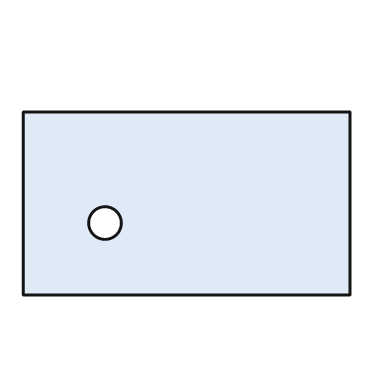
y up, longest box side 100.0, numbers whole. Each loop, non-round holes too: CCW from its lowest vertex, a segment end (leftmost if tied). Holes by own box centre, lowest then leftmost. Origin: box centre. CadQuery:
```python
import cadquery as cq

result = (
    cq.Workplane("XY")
    .moveTo(-50.0, -28.0)
    .lineTo(50.0, -28.0)
    .lineTo(50.0, 28.0)
    .lineTo(-50.0, 28.0)
    .close()
    .moveTo(-25.0, -6.0)
    .circle(5.0)
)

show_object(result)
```